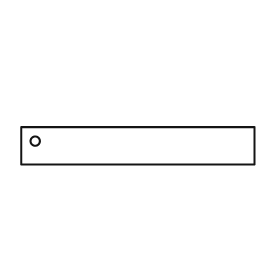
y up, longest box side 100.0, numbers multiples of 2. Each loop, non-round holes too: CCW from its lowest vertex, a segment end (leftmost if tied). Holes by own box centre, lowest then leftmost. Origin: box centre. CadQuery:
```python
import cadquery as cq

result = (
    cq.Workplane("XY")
    .moveTo(-50.0, -8.0)
    .lineTo(50.0, -8.0)
    .lineTo(50.0, 8.0)
    .lineTo(-50.0, 8.0)
    .close()
    .moveTo(-44.0, 2.0)
    .circle(2.0)
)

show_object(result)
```